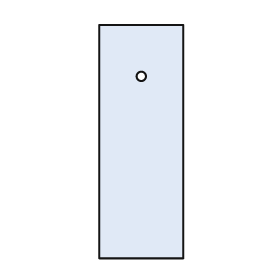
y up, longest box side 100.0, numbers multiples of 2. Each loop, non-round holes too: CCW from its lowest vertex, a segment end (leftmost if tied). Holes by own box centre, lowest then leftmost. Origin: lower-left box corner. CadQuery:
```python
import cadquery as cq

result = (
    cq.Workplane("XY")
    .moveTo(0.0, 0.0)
    .lineTo(36.0, 0.0)
    .lineTo(36.0, 100.0)
    .lineTo(0.0, 100.0)
    .close()
    .moveTo(18.0, 78.0)
    .circle(2.0)
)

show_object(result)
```